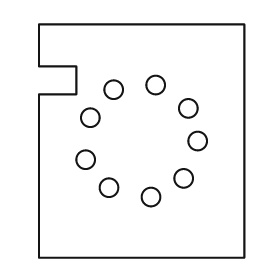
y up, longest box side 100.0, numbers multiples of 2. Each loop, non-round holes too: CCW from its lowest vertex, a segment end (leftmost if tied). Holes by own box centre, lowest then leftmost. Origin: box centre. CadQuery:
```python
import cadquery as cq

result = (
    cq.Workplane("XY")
    .moveTo(-44.0, -50.0)
    .lineTo(44.0, -50.0)
    .lineTo(44.0, 50.0)
    .lineTo(-44.0, 50.0)
    .lineTo(-44.0, 32.0)
    .lineTo(-28.0, 32.0)
    .lineTo(-28.0, 20.0)
    .lineTo(-44.0, 20.0)
    .close()
    .moveTo(4.0, -24.0)
    .circle(4.0)
    .moveTo(-14.0, -20.0)
    .circle(4.0)
    .moveTo(18.0, -16.0)
    .circle(4.0)
    .moveTo(-24.0, -8.0)
    .circle(4.0)
    .moveTo(24.0, 0.0)
    .circle(4.0)
    .moveTo(-22.0, 10.0)
    .circle(4.0)
    .moveTo(20.0, 14.0)
    .circle(4.0)
    .moveTo(-12.0, 22.0)
    .circle(4.0)
    .moveTo(6.0, 24.0)
    .circle(4.0)
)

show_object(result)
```